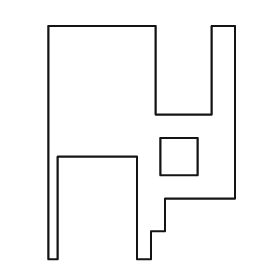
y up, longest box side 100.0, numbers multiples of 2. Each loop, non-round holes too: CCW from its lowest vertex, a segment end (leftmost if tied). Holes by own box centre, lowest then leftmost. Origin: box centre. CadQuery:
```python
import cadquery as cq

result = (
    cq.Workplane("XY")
    .moveTo(-40.0, -50.0)
    .lineTo(-36.0, -50.0)
    .lineTo(-36.0, -6.0)
    .lineTo(-2.0, -6.0)
    .lineTo(-2.0, -50.0)
    .lineTo(4.0, -50.0)
    .lineTo(4.0, -38.0)
    .lineTo(10.0, -38.0)
    .lineTo(10.0, -24.0)
    .lineTo(40.0, -24.0)
    .lineTo(40.0, 50.0)
    .lineTo(30.0, 50.0)
    .lineTo(30.0, 12.0)
    .lineTo(6.0, 12.0)
    .lineTo(6.0, 50.0)
    .lineTo(-40.0, 50.0)
    .close()
    .moveTo(8.0, -14.0)
    .lineTo(24.0, -14.0)
    .lineTo(24.0, 2.0)
    .lineTo(8.0, 2.0)
    .close()
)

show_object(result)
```